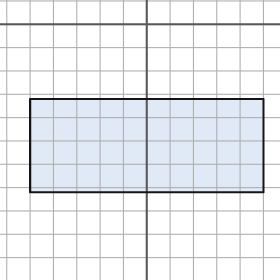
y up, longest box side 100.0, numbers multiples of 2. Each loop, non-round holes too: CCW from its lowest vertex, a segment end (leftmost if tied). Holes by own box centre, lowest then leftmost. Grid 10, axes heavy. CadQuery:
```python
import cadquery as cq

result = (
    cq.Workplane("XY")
    .moveTo(-50.0, -72.0)
    .lineTo(50.0, -72.0)
    .lineTo(50.0, -32.0)
    .lineTo(-50.0, -32.0)
    .close()
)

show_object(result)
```